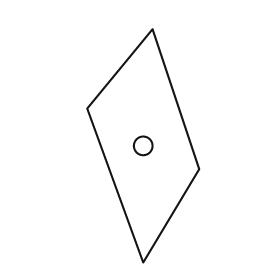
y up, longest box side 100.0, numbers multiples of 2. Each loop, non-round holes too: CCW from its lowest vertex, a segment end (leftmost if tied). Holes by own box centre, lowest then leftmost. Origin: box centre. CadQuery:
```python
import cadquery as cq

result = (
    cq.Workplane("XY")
    .moveTo(0.0, -50.0)
    .lineTo(24.0, -10.0)
    .lineTo(4.0, 50.0)
    .lineTo(-24.0, 16.0)
    .close()
    .moveTo(0.0, 0.0)
    .circle(4.0)
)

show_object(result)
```